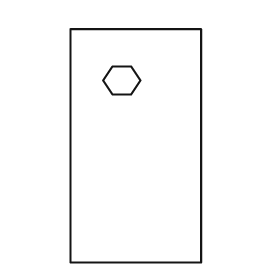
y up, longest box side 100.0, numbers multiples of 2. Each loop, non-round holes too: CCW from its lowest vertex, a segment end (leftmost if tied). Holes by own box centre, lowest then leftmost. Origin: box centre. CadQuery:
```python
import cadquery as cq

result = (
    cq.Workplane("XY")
    .moveTo(-28.0, -50.0)
    .lineTo(28.0, -50.0)
    .lineTo(28.0, 50.0)
    .lineTo(-28.0, 50.0)
    .close()
    .moveTo(-10.0, 22.0)
    .lineTo(-2.0, 22.0)
    .lineTo(2.0, 28.0)
    .lineTo(-2.0, 34.0)
    .lineTo(-10.0, 34.0)
    .lineTo(-14.0, 28.0)
    .close()
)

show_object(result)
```